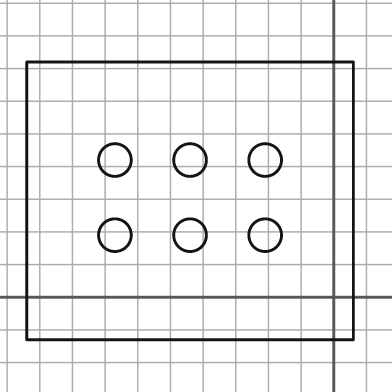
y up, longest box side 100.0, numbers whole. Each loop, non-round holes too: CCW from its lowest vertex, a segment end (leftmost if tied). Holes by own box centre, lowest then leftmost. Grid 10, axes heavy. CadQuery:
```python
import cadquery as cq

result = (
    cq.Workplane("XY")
    .moveTo(-94.0, -13.0)
    .lineTo(6.0, -13.0)
    .lineTo(6.0, 72.0)
    .lineTo(-94.0, 72.0)
    .close()
    .moveTo(-67.0, 19.0)
    .circle(5.0)
    .moveTo(-44.0, 19.0)
    .circle(5.0)
    .moveTo(-21.0, 19.0)
    .circle(5.0)
    .moveTo(-67.0, 42.0)
    .circle(5.0)
    .moveTo(-44.0, 42.0)
    .circle(5.0)
    .moveTo(-21.0, 42.0)
    .circle(5.0)
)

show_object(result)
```